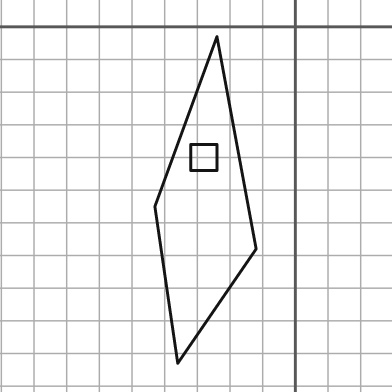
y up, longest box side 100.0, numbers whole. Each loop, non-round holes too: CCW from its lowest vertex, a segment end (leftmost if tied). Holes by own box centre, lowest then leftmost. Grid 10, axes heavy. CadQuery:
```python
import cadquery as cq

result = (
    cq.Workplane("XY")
    .moveTo(-36.0, -103.0)
    .lineTo(-12.0, -68.0)
    .lineTo(-24.0, -3.0)
    .lineTo(-43.0, -55.0)
    .close()
    .moveTo(-32.0, -44.0)
    .lineTo(-24.0, -44.0)
    .lineTo(-24.0, -36.0)
    .lineTo(-32.0, -36.0)
    .close()
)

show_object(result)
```